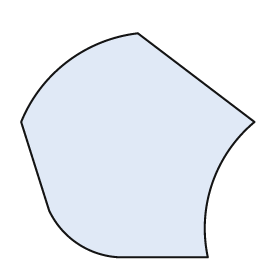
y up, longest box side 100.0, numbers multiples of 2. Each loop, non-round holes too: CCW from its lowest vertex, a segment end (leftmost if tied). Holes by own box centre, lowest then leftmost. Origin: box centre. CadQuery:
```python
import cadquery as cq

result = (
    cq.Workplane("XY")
    .moveTo(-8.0, -48.0)
    .lineTo(30.0, -48.0)
    .threePointArc((32.0, -16.0), (50.0, 10.0))
    .lineTo(0.0, 48.0)
    .threePointArc((-30.0, 36.0), (-50.0, 10.0))
    .lineTo(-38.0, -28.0)
    .threePointArc((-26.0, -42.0), (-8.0, -48.0))
    .close()
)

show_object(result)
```